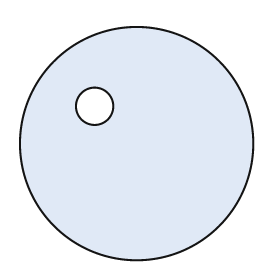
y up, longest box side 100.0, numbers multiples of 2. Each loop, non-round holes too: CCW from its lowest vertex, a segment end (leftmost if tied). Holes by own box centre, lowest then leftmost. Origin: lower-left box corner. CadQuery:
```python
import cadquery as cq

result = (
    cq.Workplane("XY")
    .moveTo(50.0, 50.0)
    .circle(50.0)
    .moveTo(32.0, 66.0)
    .circle(8.0)
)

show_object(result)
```